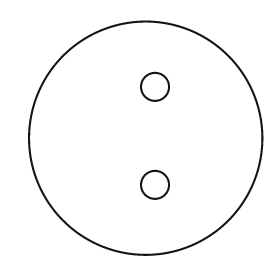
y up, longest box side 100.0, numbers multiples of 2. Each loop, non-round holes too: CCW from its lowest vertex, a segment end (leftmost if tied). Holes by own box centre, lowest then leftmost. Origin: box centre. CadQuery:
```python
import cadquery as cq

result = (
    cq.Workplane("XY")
    .moveTo(0.0, 0.0)
    .circle(50.0)
    .moveTo(4.0, -20.0)
    .circle(6.0)
    .moveTo(4.0, 22.0)
    .circle(6.0)
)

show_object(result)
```